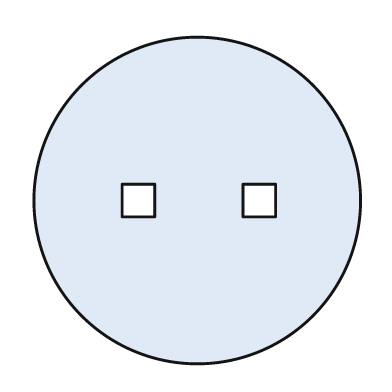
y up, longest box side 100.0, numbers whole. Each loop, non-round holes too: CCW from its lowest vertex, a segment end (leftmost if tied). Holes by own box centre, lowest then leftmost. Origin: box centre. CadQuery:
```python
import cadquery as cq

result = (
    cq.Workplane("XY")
    .moveTo(0.0, 0.0)
    .circle(50.0)
    .moveTo(-23.0, -5.0)
    .lineTo(-13.0, -5.0)
    .lineTo(-13.0, 5.0)
    .lineTo(-23.0, 5.0)
    .close()
    .moveTo(14.0, -5.0)
    .lineTo(24.0, -5.0)
    .lineTo(24.0, 5.0)
    .lineTo(14.0, 5.0)
    .close()
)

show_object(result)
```